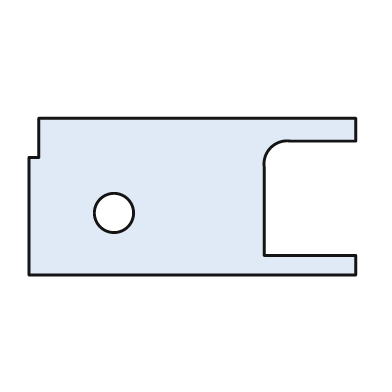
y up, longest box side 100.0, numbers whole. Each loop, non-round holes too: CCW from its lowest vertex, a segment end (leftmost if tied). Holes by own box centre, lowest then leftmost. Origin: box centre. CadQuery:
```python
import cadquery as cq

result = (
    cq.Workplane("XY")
    .moveTo(-50.0, -24.0)
    .lineTo(50.0, -24.0)
    .lineTo(50.0, -18.0)
    .lineTo(22.0, -18.0)
    .lineTo(22.0, 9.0)
    .threePointArc((24.0, 15.0), (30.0, 17.0))
    .lineTo(50.0, 17.0)
    .lineTo(50.0, 24.0)
    .lineTo(-47.0, 24.0)
    .lineTo(-47.0, 12.0)
    .lineTo(-50.0, 12.0)
    .close()
    .moveTo(-24.0, -5.0)
    .circle(6.0)
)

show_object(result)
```